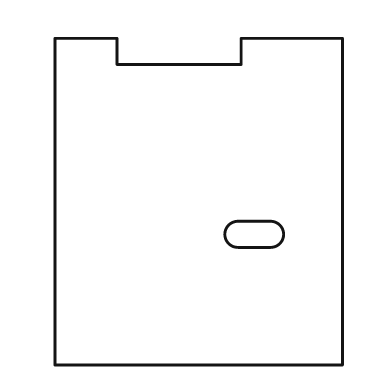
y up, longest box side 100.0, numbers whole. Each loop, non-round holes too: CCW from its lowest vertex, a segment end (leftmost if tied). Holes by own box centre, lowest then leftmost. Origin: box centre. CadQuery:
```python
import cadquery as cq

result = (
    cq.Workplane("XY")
    .moveTo(-44.0, -50.0)
    .lineTo(44.0, -50.0)
    .lineTo(44.0, 50.0)
    .lineTo(13.0, 50.0)
    .lineTo(13.0, 42.0)
    .lineTo(-25.0, 42.0)
    .lineTo(-25.0, 50.0)
    .lineTo(-44.0, 50.0)
    .close()
    .moveTo(12.0, -14.0)
    .lineTo(22.0, -14.0)
    .threePointArc((26.0, -10.0), (22.0, -6.0))
    .lineTo(12.0, -6.0)
    .threePointArc((8.0, -10.0), (12.0, -14.0))
    .close()
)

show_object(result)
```